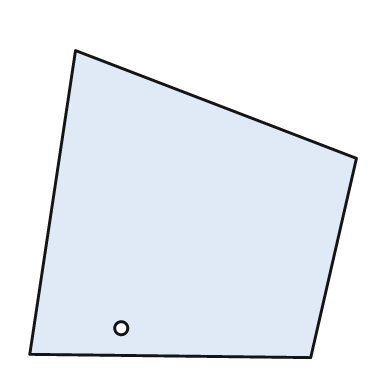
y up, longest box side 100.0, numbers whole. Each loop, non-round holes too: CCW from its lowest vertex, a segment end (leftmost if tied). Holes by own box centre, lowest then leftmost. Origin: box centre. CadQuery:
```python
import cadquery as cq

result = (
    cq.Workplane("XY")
    .moveTo(36.0, -47.0)
    .lineTo(50.0, 14.0)
    .lineTo(-36.0, 47.0)
    .lineTo(-50.0, -46.0)
    .close()
    .moveTo(-22.0, -38.0)
    .circle(2.0)
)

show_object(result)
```